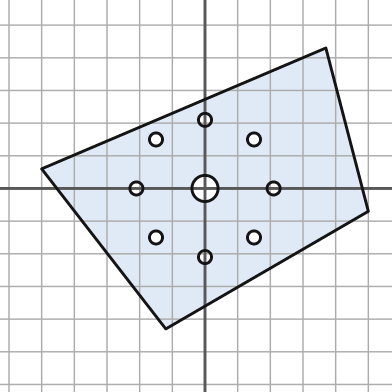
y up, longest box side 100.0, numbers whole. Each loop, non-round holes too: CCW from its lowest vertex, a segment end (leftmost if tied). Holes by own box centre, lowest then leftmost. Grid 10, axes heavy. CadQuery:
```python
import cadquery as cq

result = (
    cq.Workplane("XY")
    .moveTo(-12.0, -43.0)
    .lineTo(50.0, -7.0)
    .lineTo(37.0, 43.0)
    .lineTo(-50.0, 6.0)
    .close()
    .moveTo(0.0, -21.0)
    .circle(2.0)
    .moveTo(-15.0, -15.0)
    .circle(2.0)
    .moveTo(15.0, -15.0)
    .circle(2.0)
    .moveTo(-21.0, 0.0)
    .circle(2.0)
    .moveTo(0.0, 0.0)
    .circle(4.0)
    .moveTo(21.0, 0.0)
    .circle(2.0)
    .moveTo(-15.0, 15.0)
    .circle(2.0)
    .moveTo(15.0, 15.0)
    .circle(2.0)
    .moveTo(0.0, 21.0)
    .circle(2.0)
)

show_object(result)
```